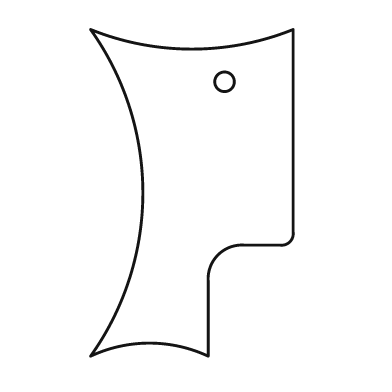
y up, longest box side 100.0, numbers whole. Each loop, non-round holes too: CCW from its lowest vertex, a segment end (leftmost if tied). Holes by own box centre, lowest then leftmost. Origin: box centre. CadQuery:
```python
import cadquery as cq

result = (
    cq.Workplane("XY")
    .moveTo(-31.0, -50.0)
    .threePointArc((-13.0, -46.0), (5.0, -50.0))
    .lineTo(5.0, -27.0)
    .threePointArc((8.0, -19.0), (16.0, -16.0))
    .lineTo(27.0, -16.0)
    .threePointArc((30.0, -15.0), (31.0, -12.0))
    .lineTo(31.0, 50.0)
    .threePointArc((0.0, 44.0), (-31.0, 50.0))
    .threePointArc((-15.0, 0.0), (-31.0, -50.0))
    .close()
    .moveTo(10.0, 34.0)
    .circle(3.0)
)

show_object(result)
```